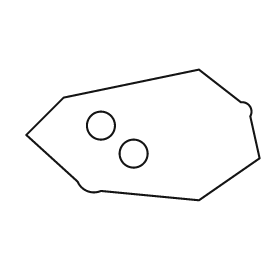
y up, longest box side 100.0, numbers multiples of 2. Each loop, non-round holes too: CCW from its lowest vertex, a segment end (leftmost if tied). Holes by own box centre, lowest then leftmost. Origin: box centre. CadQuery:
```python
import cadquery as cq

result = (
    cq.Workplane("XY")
    .moveTo(24.0, -28.0)
    .lineTo(50.0, -10.0)
    .lineTo(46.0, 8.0)
    .threePointArc((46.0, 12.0), (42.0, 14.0))
    .lineTo(24.0, 28.0)
    .lineTo(-34.0, 16.0)
    .lineTo(-50.0, 0.0)
    .lineTo(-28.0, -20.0)
    .threePointArc((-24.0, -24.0), (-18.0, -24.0))
    .close()
    .moveTo(-4.0, -8.0)
    .circle(6.0)
    .moveTo(-18.0, 4.0)
    .circle(6.0)
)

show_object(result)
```